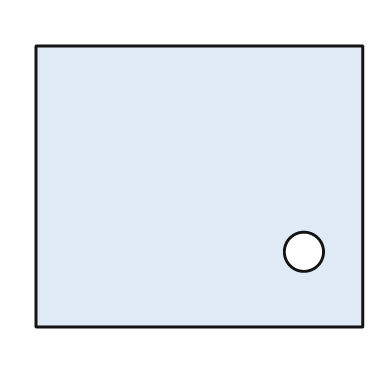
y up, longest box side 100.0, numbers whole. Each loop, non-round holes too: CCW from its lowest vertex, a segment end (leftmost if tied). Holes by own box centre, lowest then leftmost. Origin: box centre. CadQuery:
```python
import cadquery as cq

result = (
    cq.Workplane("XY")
    .moveTo(-50.0, -43.0)
    .lineTo(50.0, -43.0)
    .lineTo(50.0, 43.0)
    .lineTo(-50.0, 43.0)
    .close()
    .moveTo(32.0, -20.0)
    .circle(6.0)
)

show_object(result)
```